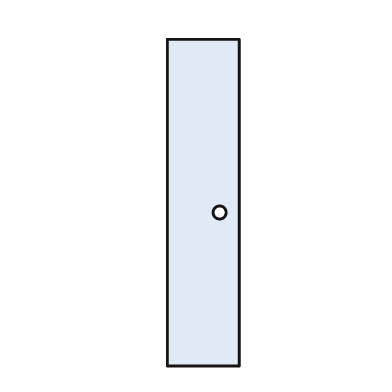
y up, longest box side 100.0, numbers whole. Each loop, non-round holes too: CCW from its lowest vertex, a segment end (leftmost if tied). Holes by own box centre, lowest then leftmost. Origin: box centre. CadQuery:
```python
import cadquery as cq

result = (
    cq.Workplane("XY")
    .moveTo(-11.0, -50.0)
    .lineTo(11.0, -50.0)
    .lineTo(11.0, 50.0)
    .lineTo(-11.0, 50.0)
    .close()
    .moveTo(5.0, -3.0)
    .circle(2.0)
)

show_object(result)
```